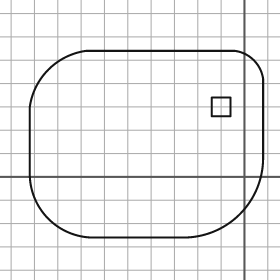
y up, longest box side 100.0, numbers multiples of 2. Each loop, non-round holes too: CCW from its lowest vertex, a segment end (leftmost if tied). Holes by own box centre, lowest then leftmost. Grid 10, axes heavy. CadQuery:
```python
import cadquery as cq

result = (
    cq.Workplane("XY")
    .moveTo(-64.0, -26.0)
    .lineTo(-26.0, -26.0)
    .threePointArc((-2.0, -16.0), (8.0, 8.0))
    .lineTo(8.0, 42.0)
    .threePointArc((4.0, 50.0), (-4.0, 54.0))
    .lineTo(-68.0, 54.0)
    .threePointArc((-84.0, 46.0), (-92.0, 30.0))
    .lineTo(-92.0, 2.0)
    .threePointArc((-84.0, -18.0), (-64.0, -26.0))
    .close()
    .moveTo(-14.0, 26.0)
    .lineTo(-6.0, 26.0)
    .lineTo(-6.0, 34.0)
    .lineTo(-14.0, 34.0)
    .close()
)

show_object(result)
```